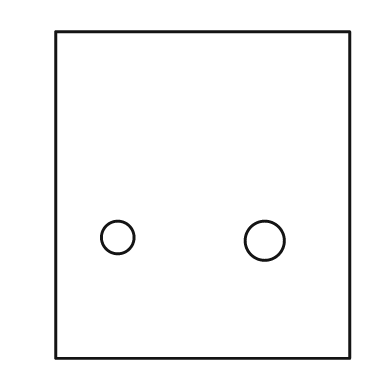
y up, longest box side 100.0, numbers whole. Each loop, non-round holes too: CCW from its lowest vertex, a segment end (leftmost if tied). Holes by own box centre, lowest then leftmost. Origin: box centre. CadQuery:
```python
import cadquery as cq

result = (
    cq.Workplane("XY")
    .moveTo(-45.0, -50.0)
    .lineTo(45.0, -50.0)
    .lineTo(45.0, 50.0)
    .lineTo(-45.0, 50.0)
    .close()
    .moveTo(19.0, -14.0)
    .circle(6.0)
    .moveTo(-26.0, -13.0)
    .circle(5.0)
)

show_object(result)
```